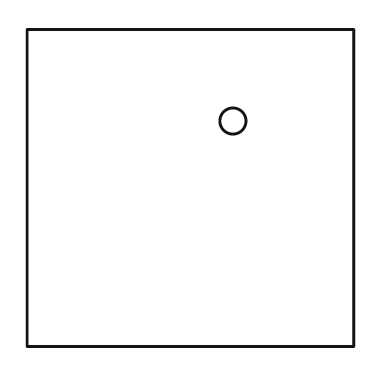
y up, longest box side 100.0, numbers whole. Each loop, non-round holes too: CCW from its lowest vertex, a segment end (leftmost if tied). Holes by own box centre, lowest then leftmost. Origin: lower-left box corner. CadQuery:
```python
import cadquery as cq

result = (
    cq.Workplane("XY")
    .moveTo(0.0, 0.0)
    .lineTo(100.0, 0.0)
    .lineTo(100.0, 97.0)
    .lineTo(0.0, 97.0)
    .close()
    .moveTo(63.0, 69.0)
    .circle(4.0)
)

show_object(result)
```